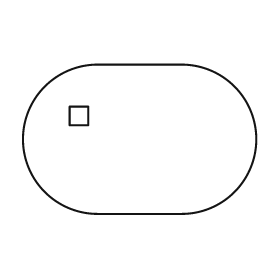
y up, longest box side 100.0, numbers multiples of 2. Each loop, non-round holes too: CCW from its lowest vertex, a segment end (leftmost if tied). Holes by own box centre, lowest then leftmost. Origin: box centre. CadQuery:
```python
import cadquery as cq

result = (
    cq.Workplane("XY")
    .moveTo(-18.0, -32.0)
    .lineTo(18.0, -32.0)
    .threePointArc((50.0, 0.0), (18.0, 32.0))
    .lineTo(-18.0, 32.0)
    .threePointArc((-50.0, 0.0), (-18.0, -32.0))
    .close()
    .moveTo(-30.0, 6.0)
    .lineTo(-22.0, 6.0)
    .lineTo(-22.0, 14.0)
    .lineTo(-30.0, 14.0)
    .close()
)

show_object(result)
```